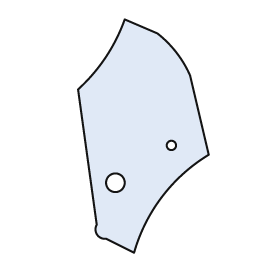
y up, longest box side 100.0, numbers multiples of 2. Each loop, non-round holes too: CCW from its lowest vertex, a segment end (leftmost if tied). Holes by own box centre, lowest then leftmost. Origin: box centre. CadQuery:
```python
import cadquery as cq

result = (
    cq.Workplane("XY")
    .moveTo(-4.0, -50.0)
    .threePointArc((8.0, -26.0), (28.0, -8.0))
    .lineTo(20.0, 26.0)
    .threePointArc((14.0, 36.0), (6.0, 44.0))
    .lineTo(-8.0, 50.0)
    .threePointArc((-16.0, 34.0), (-28.0, 20.0))
    .lineTo(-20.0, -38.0)
    .threePointArc((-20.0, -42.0), (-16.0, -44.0))
    .close()
    .moveTo(-12.0, -20.0)
    .circle(4.0)
    .moveTo(12.0, -4.0)
    .circle(2.0)
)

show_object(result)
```